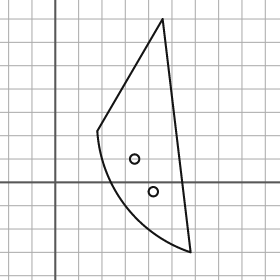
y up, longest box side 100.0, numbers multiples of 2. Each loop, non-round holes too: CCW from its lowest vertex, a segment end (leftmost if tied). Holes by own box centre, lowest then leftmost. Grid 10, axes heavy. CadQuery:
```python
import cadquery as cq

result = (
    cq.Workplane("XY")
    .moveTo(58.0, -30.0)
    .lineTo(46.0, 70.0)
    .lineTo(18.0, 22.0)
    .threePointArc((30.0, -10.0), (58.0, -30.0))
    .close()
    .moveTo(42.0, -4.0)
    .circle(2.0)
    .moveTo(34.0, 10.0)
    .circle(2.0)
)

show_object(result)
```